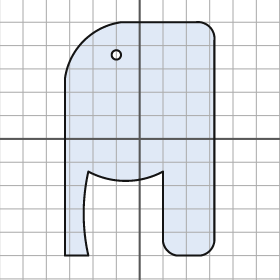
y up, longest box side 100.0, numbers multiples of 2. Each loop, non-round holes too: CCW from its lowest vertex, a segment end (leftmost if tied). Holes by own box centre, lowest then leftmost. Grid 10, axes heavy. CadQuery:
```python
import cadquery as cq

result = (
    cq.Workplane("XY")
    .moveTo(-32.0, -50.0)
    .lineTo(-22.0, -50.0)
    .threePointArc((-24.0, -32.0), (-22.0, -14.0))
    .threePointArc((-6.0, -18.0), (10.0, -14.0))
    .lineTo(10.0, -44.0)
    .threePointArc((12.0, -48.0), (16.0, -50.0))
    .lineTo(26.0, -50.0)
    .threePointArc((30.0, -48.0), (32.0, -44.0))
    .lineTo(32.0, 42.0)
    .threePointArc((30.0, 48.0), (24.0, 50.0))
    .lineTo(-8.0, 50.0)
    .threePointArc((-24.0, 42.0), (-32.0, 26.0))
    .close()
    .moveTo(-10.0, 36.0)
    .circle(2.0)
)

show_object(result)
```